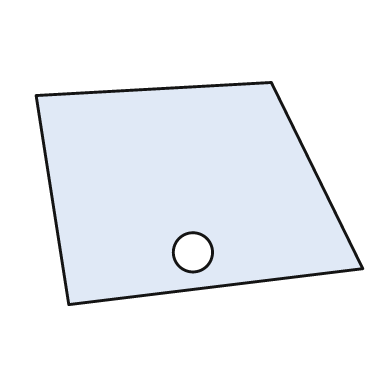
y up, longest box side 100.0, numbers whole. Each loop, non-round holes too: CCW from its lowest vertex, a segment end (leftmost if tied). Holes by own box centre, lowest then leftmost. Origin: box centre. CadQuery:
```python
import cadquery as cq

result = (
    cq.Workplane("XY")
    .moveTo(-40.0, -34.0)
    .lineTo(50.0, -23.0)
    .lineTo(22.0, 34.0)
    .lineTo(-50.0, 30.0)
    .close()
    .moveTo(-2.0, -18.0)
    .circle(6.0)
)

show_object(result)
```